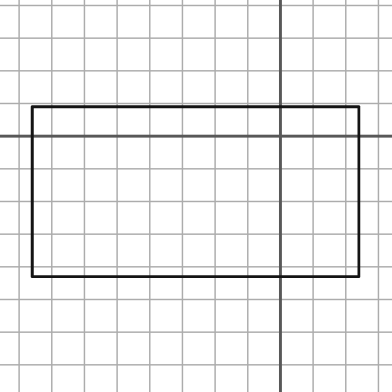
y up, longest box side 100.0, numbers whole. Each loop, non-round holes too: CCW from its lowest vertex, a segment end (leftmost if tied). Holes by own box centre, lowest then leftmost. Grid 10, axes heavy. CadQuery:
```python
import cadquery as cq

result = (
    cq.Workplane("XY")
    .moveTo(-76.0, -43.0)
    .lineTo(24.0, -43.0)
    .lineTo(24.0, 9.0)
    .lineTo(-76.0, 9.0)
    .close()
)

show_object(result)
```